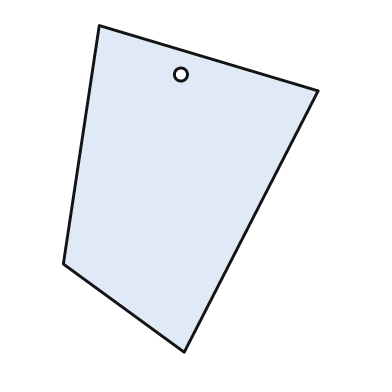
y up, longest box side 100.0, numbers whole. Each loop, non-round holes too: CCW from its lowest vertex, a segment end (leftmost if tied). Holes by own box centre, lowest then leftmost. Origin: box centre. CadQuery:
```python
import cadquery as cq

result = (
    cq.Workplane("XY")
    .moveTo(-2.0, -50.0)
    .lineTo(39.0, 30.0)
    .lineTo(-28.0, 50.0)
    .lineTo(-39.0, -23.0)
    .close()
    .moveTo(-3.0, 35.0)
    .circle(2.0)
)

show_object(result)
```